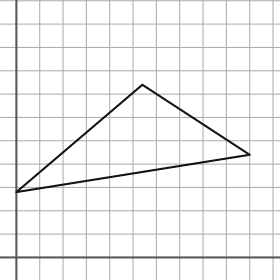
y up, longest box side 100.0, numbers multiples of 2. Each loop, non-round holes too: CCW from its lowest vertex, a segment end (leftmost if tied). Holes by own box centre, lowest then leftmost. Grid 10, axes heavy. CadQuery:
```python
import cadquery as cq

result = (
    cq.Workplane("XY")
    .moveTo(0.0, 28.0)
    .lineTo(100.0, 44.0)
    .lineTo(54.0, 74.0)
    .close()
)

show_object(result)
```